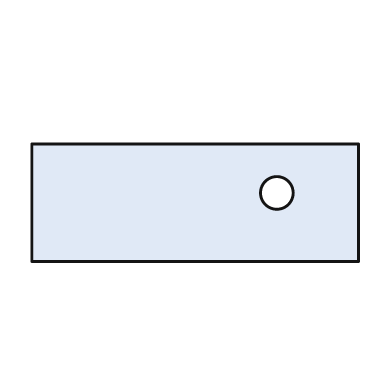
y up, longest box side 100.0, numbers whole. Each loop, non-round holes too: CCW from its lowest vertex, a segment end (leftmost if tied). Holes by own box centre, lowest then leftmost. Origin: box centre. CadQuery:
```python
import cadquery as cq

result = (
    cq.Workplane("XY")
    .moveTo(-50.0, -18.0)
    .lineTo(50.0, -18.0)
    .lineTo(50.0, 18.0)
    .lineTo(-50.0, 18.0)
    .close()
    .moveTo(25.0, 3.0)
    .circle(5.0)
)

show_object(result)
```